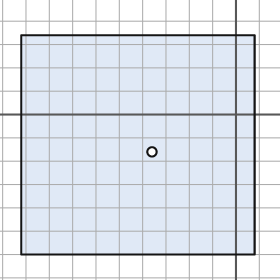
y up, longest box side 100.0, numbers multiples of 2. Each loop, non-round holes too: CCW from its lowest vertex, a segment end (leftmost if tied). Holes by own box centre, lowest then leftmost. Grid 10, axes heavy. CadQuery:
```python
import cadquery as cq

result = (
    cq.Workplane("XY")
    .moveTo(-92.0, -60.0)
    .lineTo(8.0, -60.0)
    .lineTo(8.0, 34.0)
    .lineTo(-92.0, 34.0)
    .close()
    .moveTo(-36.0, -16.0)
    .circle(2.0)
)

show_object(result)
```